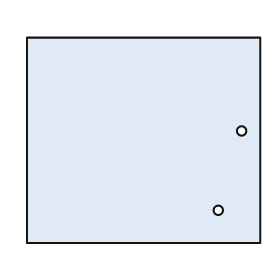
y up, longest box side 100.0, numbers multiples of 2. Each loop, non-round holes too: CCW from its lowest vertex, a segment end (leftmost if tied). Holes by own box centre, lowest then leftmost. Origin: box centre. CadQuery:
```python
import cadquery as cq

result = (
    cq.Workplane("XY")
    .moveTo(-50.0, -44.0)
    .lineTo(50.0, -44.0)
    .lineTo(50.0, 44.0)
    .lineTo(-50.0, 44.0)
    .close()
    .moveTo(32.0, -30.0)
    .circle(2.0)
    .moveTo(42.0, 4.0)
    .circle(2.0)
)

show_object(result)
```